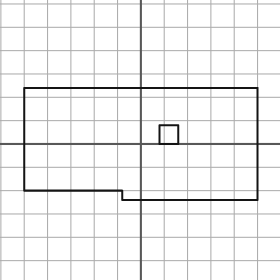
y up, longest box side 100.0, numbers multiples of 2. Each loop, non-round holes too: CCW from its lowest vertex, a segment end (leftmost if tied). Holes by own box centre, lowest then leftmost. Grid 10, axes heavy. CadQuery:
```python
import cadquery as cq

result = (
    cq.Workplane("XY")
    .moveTo(-8.0, -24.0)
    .lineTo(50.0, -24.0)
    .lineTo(50.0, 24.0)
    .lineTo(-50.0, 24.0)
    .lineTo(-50.0, -20.0)
    .lineTo(-8.0, -20.0)
    .close()
    .moveTo(8.0, 0.0)
    .lineTo(16.0, 0.0)
    .lineTo(16.0, 8.0)
    .lineTo(8.0, 8.0)
    .close()
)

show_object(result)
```